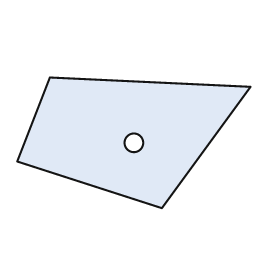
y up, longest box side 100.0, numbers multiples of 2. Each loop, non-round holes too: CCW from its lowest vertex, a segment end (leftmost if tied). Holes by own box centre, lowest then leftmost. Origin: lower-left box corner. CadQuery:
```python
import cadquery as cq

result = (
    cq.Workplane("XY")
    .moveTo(62.0, 0.0)
    .lineTo(100.0, 52.0)
    .lineTo(14.0, 56.0)
    .lineTo(0.0, 20.0)
    .close()
    .moveTo(50.0, 28.0)
    .circle(4.0)
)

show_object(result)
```